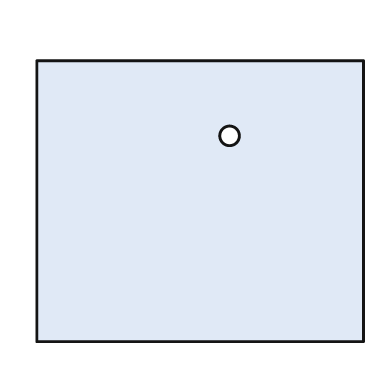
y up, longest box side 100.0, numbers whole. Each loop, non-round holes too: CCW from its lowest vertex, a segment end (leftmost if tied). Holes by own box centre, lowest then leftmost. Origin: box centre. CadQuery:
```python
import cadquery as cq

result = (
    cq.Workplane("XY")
    .moveTo(-50.0, -43.0)
    .lineTo(50.0, -43.0)
    .lineTo(50.0, 43.0)
    .lineTo(-50.0, 43.0)
    .close()
    .moveTo(9.0, 20.0)
    .circle(3.0)
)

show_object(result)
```